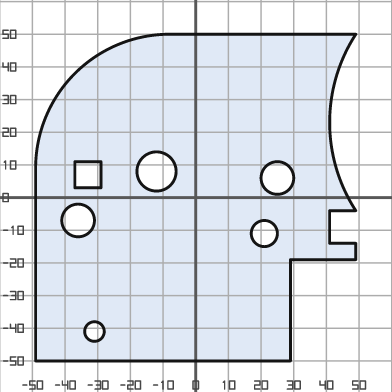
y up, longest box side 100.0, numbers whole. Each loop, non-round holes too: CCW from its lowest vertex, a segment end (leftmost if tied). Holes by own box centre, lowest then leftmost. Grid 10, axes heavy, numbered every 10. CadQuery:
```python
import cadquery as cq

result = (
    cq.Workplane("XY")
    .moveTo(-49.0, -50.0)
    .lineTo(29.0, -50.0)
    .lineTo(29.0, -19.0)
    .lineTo(49.0, -19.0)
    .lineTo(49.0, -14.0)
    .lineTo(41.0, -14.0)
    .lineTo(41.0, -4.0)
    .lineTo(49.0, -4.0)
    .threePointArc((41.0, 23.0), (49.0, 50.0))
    .lineTo(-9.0, 50.0)
    .threePointArc((-37.0, 38.0), (-49.0, 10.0))
    .close()
    .moveTo(-31.0, -41.0)
    .circle(3.0)
    .moveTo(21.0, -11.0)
    .circle(4.0)
    .moveTo(-36.0, -7.0)
    .circle(5.0)
    .moveTo(25.0, 6.0)
    .circle(5.0)
    .moveTo(-37.0, 3.0)
    .lineTo(-29.0, 3.0)
    .lineTo(-29.0, 11.0)
    .lineTo(-37.0, 11.0)
    .close()
    .moveTo(-12.0, 8.0)
    .circle(6.0)
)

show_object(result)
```